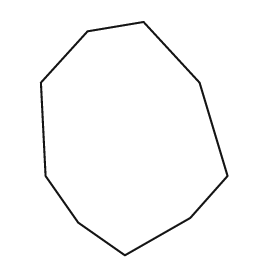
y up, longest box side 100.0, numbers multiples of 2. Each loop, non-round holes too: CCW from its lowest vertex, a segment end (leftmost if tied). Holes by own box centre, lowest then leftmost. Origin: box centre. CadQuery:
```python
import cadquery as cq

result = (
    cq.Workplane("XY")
    .moveTo(-4.0, -50.0)
    .lineTo(24.0, -34.0)
    .lineTo(40.0, -16.0)
    .lineTo(28.0, 24.0)
    .lineTo(4.0, 50.0)
    .lineTo(-20.0, 46.0)
    .lineTo(-40.0, 24.0)
    .lineTo(-38.0, -16.0)
    .lineTo(-24.0, -36.0)
    .close()
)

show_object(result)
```